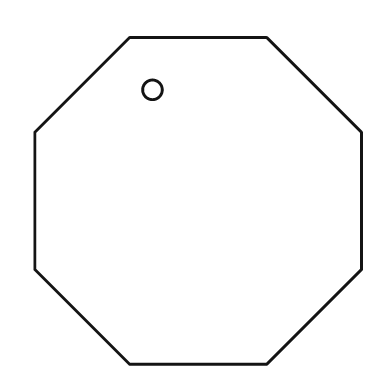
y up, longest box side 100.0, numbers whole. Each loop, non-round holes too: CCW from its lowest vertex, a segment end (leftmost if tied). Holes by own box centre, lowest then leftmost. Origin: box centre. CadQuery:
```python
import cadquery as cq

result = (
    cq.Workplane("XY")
    .moveTo(-21.0, -50.0)
    .lineTo(21.0, -50.0)
    .lineTo(50.0, -21.0)
    .lineTo(50.0, 21.0)
    .lineTo(21.0, 50.0)
    .lineTo(-21.0, 50.0)
    .lineTo(-50.0, 21.0)
    .lineTo(-50.0, -21.0)
    .close()
    .moveTo(-14.0, 34.0)
    .circle(3.0)
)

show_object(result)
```